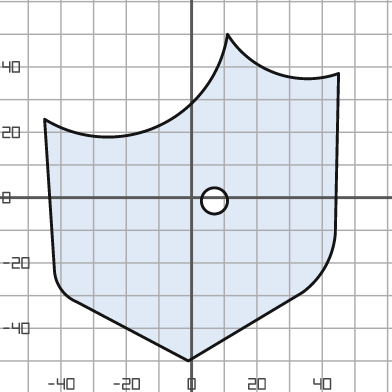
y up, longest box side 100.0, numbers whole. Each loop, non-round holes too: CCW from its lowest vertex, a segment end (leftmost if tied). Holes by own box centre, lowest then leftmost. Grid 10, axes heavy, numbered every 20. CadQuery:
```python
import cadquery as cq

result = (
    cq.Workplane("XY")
    .moveTo(-1.0, -50.0)
    .lineTo(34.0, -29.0)
    .threePointArc((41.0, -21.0), (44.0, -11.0))
    .lineTo(45.0, 38.0)
    .threePointArc((26.0, 38.0), (11.0, 50.0))
    .threePointArc((-10.0, 22.0), (-45.0, 24.0))
    .lineTo(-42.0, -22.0)
    .threePointArc((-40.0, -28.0), (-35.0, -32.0))
    .close()
    .moveTo(7.0, -1.0)
    .circle(4.0)
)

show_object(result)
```